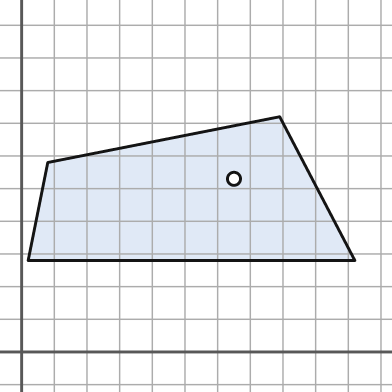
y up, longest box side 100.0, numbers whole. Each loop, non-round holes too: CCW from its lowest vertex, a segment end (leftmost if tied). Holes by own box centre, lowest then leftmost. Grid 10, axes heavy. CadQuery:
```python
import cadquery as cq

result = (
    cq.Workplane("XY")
    .moveTo(2.0, 28.0)
    .lineTo(102.0, 28.0)
    .lineTo(79.0, 72.0)
    .lineTo(8.0, 58.0)
    .close()
    .moveTo(65.0, 53.0)
    .circle(2.0)
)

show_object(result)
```